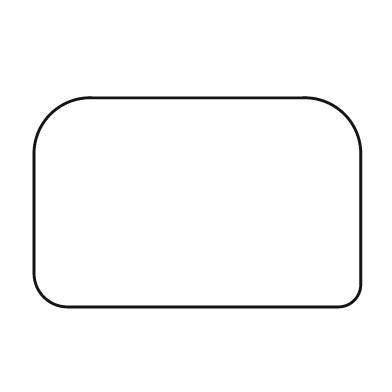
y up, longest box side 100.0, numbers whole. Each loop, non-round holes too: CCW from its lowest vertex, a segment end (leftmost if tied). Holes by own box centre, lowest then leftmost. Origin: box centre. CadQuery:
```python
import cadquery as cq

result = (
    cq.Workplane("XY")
    .moveTo(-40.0, -32.0)
    .lineTo(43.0, -32.0)
    .threePointArc((48.0, -30.0), (50.0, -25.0))
    .lineTo(50.0, 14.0)
    .threePointArc((45.0, 27.0), (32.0, 32.0))
    .lineTo(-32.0, 32.0)
    .threePointArc((-45.0, 27.0), (-50.0, 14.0))
    .lineTo(-50.0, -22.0)
    .threePointArc((-47.0, -29.0), (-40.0, -32.0))
    .close()
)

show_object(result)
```